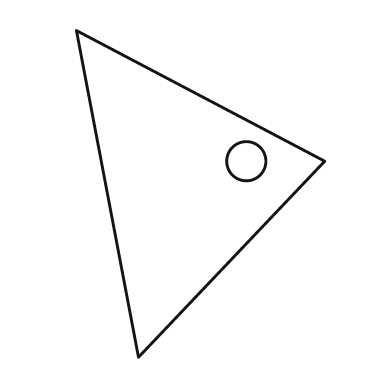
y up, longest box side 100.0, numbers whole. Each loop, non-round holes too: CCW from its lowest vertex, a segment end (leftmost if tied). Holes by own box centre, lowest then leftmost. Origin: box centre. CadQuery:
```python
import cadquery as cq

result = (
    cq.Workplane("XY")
    .moveTo(-19.0, -50.0)
    .lineTo(38.0, 10.0)
    .lineTo(-38.0, 50.0)
    .close()
    .moveTo(14.0, 10.0)
    .circle(6.0)
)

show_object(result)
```